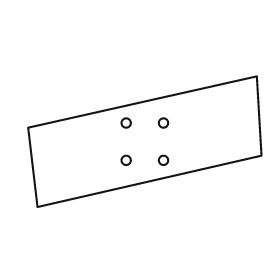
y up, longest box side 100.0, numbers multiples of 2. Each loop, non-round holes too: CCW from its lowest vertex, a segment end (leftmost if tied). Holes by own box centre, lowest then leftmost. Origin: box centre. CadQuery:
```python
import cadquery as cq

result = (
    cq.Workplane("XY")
    .moveTo(-46.0, -28.0)
    .lineTo(50.0, -6.0)
    .lineTo(48.0, 28.0)
    .lineTo(-50.0, 6.0)
    .close()
    .moveTo(-8.0, -8.0)
    .circle(2.0)
    .moveTo(8.0, -8.0)
    .circle(2.0)
    .moveTo(-8.0, 8.0)
    .circle(2.0)
    .moveTo(8.0, 8.0)
    .circle(2.0)
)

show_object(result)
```